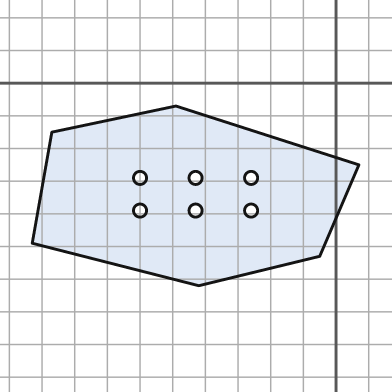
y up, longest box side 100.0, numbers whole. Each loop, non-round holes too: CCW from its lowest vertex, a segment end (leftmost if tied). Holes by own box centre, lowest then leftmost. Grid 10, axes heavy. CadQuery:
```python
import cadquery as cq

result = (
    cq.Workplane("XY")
    .moveTo(-42.0, -62.0)
    .lineTo(-5.0, -53.0)
    .lineTo(7.0, -25.0)
    .lineTo(-49.0, -7.0)
    .lineTo(-87.0, -15.0)
    .lineTo(-93.0, -49.0)
    .close()
    .moveTo(-60.0, -39.0)
    .circle(2.0)
    .moveTo(-43.0, -39.0)
    .circle(2.0)
    .moveTo(-26.0, -39.0)
    .circle(2.0)
    .moveTo(-60.0, -29.0)
    .circle(2.0)
    .moveTo(-43.0, -29.0)
    .circle(2.0)
    .moveTo(-26.0, -29.0)
    .circle(2.0)
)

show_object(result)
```